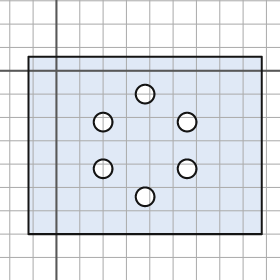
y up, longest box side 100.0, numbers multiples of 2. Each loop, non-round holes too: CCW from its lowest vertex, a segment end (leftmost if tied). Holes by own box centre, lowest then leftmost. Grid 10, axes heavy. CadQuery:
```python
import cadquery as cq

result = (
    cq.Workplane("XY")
    .moveTo(-12.0, -70.0)
    .lineTo(88.0, -70.0)
    .lineTo(88.0, 6.0)
    .lineTo(-12.0, 6.0)
    .close()
    .moveTo(38.0, -54.0)
    .circle(4.0)
    .moveTo(20.0, -42.0)
    .circle(4.0)
    .moveTo(56.0, -42.0)
    .circle(4.0)
    .moveTo(20.0, -22.0)
    .circle(4.0)
    .moveTo(56.0, -22.0)
    .circle(4.0)
    .moveTo(38.0, -10.0)
    .circle(4.0)
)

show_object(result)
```